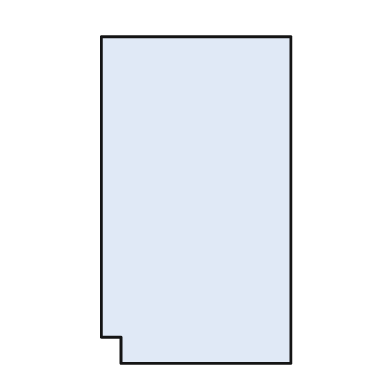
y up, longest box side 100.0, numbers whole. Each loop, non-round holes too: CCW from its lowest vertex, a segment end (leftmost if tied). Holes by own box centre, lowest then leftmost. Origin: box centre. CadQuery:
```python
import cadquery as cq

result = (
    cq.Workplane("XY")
    .moveTo(-23.0, -50.0)
    .lineTo(29.0, -50.0)
    .lineTo(29.0, 50.0)
    .lineTo(-29.0, 50.0)
    .lineTo(-29.0, -42.0)
    .lineTo(-23.0, -42.0)
    .close()
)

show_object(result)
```